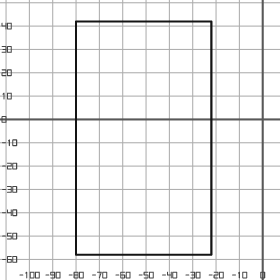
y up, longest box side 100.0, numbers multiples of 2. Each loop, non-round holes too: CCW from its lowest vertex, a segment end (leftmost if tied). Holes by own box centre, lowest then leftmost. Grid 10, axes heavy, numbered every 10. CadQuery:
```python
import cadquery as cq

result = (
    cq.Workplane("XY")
    .moveTo(-80.0, -58.0)
    .lineTo(-22.0, -58.0)
    .lineTo(-22.0, 42.0)
    .lineTo(-80.0, 42.0)
    .close()
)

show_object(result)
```